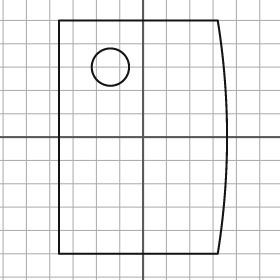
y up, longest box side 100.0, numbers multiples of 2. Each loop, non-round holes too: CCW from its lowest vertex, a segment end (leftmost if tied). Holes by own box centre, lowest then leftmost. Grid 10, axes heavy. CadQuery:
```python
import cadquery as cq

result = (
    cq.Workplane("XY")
    .moveTo(-36.0, -50.0)
    .lineTo(32.0, -50.0)
    .threePointArc((36.0, 0.0), (32.0, 50.0))
    .lineTo(-36.0, 50.0)
    .close()
    .moveTo(-14.0, 30.0)
    .circle(8.0)
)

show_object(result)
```